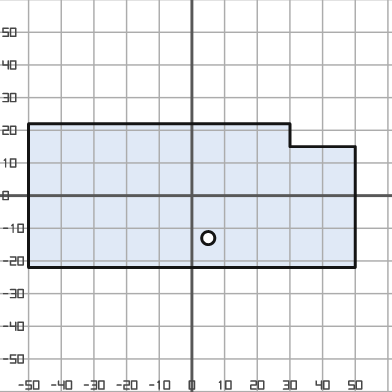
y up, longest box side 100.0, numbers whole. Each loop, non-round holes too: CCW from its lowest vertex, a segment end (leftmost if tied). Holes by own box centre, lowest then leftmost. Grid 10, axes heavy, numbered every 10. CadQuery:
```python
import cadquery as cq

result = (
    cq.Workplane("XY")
    .moveTo(-50.0, -22.0)
    .lineTo(50.0, -22.0)
    .lineTo(50.0, 15.0)
    .lineTo(30.0, 15.0)
    .lineTo(30.0, 22.0)
    .lineTo(-50.0, 22.0)
    .close()
    .moveTo(5.0, -13.0)
    .circle(2.0)
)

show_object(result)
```